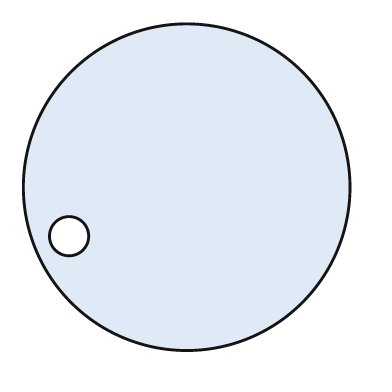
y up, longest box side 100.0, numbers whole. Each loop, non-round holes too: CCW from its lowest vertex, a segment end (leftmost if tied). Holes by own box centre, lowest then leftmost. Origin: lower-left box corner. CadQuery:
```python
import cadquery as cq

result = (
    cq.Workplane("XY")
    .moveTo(50.0, 50.0)
    .circle(50.0)
    .moveTo(14.0, 35.0)
    .circle(6.0)
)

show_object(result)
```